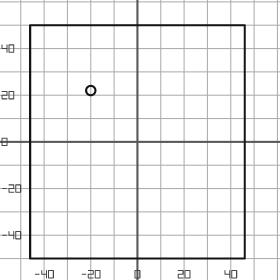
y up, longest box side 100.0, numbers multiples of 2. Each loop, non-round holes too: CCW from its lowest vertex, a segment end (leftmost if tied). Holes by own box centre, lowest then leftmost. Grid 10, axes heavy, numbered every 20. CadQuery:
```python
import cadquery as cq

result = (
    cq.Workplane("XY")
    .moveTo(-46.0, -50.0)
    .lineTo(46.0, -50.0)
    .lineTo(46.0, 50.0)
    .lineTo(-46.0, 50.0)
    .close()
    .moveTo(-20.0, 22.0)
    .circle(2.0)
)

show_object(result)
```